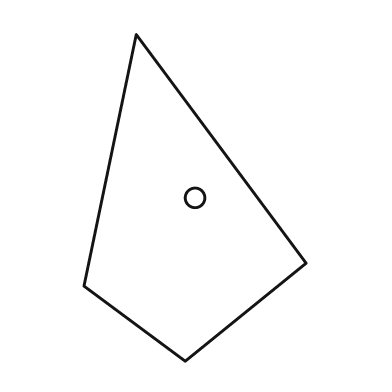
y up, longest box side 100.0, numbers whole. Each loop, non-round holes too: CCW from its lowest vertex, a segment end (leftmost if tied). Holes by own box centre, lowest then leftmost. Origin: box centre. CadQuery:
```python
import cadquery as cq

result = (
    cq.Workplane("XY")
    .moveTo(-3.0, -50.0)
    .lineTo(34.0, -20.0)
    .lineTo(-18.0, 50.0)
    .lineTo(-34.0, -27.0)
    .close()
    .moveTo(0.0, 0.0)
    .circle(3.0)
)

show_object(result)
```